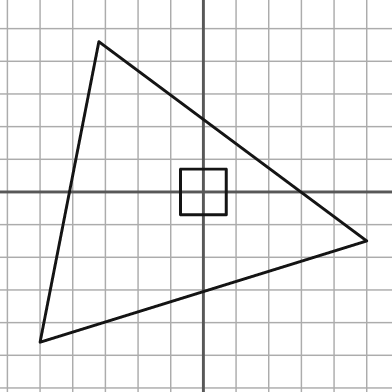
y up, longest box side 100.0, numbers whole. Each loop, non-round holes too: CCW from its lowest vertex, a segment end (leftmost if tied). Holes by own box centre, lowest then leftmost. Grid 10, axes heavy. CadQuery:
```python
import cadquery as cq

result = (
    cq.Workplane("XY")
    .moveTo(-50.0, -46.0)
    .lineTo(50.0, -15.0)
    .lineTo(-32.0, 46.0)
    .close()
    .moveTo(-7.0, -7.0)
    .lineTo(7.0, -7.0)
    .lineTo(7.0, 7.0)
    .lineTo(-7.0, 7.0)
    .close()
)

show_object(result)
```